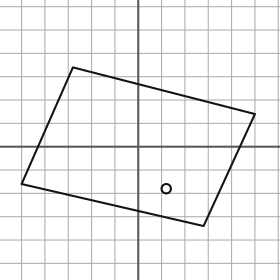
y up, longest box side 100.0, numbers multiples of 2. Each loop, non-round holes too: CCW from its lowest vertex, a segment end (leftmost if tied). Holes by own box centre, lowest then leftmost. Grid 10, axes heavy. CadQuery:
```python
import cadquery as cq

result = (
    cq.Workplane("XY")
    .moveTo(28.0, -34.0)
    .lineTo(50.0, 14.0)
    .lineTo(-28.0, 34.0)
    .lineTo(-50.0, -16.0)
    .close()
    .moveTo(12.0, -18.0)
    .circle(2.0)
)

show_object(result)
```